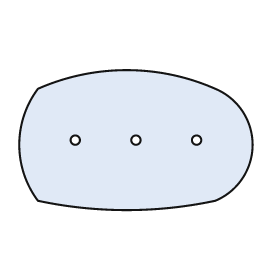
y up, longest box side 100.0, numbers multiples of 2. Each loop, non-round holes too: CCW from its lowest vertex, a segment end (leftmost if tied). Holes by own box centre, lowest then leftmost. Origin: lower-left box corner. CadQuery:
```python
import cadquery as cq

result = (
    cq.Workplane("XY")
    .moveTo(8.0, 4.0)
    .threePointArc((46.0, 0.0), (84.0, 4.0))
    .threePointArc((100.0, 28.0), (84.0, 52.0))
    .threePointArc((46.0, 60.0), (8.0, 52.0))
    .threePointArc((0.0, 28.0), (8.0, 4.0))
    .close()
    .moveTo(24.0, 30.0)
    .circle(2.0)
    .moveTo(50.0, 30.0)
    .circle(2.0)
    .moveTo(76.0, 30.0)
    .circle(2.0)
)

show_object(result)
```